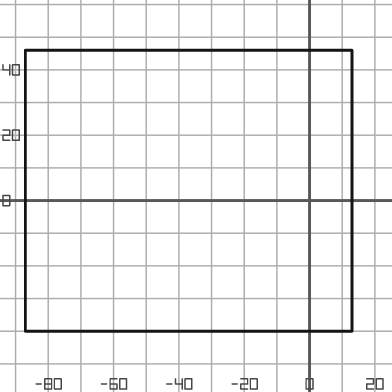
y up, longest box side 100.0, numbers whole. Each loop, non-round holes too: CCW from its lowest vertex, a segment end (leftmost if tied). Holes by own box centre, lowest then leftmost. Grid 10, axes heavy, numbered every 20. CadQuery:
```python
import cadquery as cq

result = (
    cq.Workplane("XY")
    .moveTo(-87.0, -40.0)
    .lineTo(13.0, -40.0)
    .lineTo(13.0, 46.0)
    .lineTo(-87.0, 46.0)
    .close()
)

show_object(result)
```